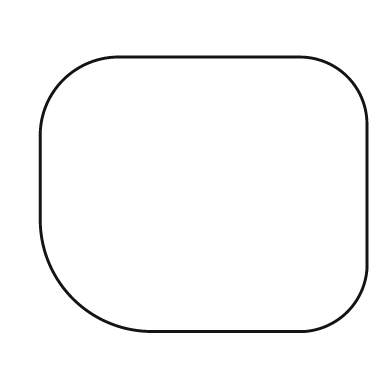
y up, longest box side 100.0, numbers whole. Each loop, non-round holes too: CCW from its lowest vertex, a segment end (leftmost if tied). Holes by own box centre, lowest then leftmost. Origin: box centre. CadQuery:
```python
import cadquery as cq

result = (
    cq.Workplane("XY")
    .moveTo(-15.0, -42.0)
    .lineTo(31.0, -42.0)
    .threePointArc((44.0, -36.0), (50.0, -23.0))
    .lineTo(50.0, 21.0)
    .threePointArc((44.0, 36.0), (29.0, 42.0))
    .lineTo(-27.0, 42.0)
    .threePointArc((-43.0, 35.0), (-50.0, 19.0))
    .lineTo(-50.0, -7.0)
    .threePointArc((-40.0, -32.0), (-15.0, -42.0))
    .close()
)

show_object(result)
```